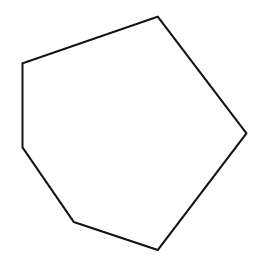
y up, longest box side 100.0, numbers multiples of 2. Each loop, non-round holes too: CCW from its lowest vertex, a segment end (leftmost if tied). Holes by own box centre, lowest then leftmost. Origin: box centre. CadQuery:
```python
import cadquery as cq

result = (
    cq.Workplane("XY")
    .moveTo(10.0, -50.0)
    .lineTo(48.0, 0.0)
    .lineTo(10.0, 50.0)
    .lineTo(-48.0, 30.0)
    .lineTo(-48.0, -6.0)
    .lineTo(-26.0, -38.0)
    .close()
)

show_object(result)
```